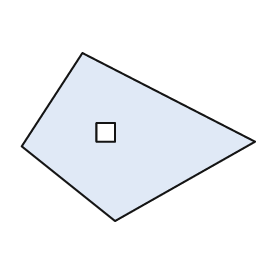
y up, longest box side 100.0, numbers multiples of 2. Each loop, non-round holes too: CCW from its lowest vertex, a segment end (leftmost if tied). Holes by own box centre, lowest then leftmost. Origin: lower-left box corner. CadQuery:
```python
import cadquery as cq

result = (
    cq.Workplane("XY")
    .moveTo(40.0, 0.0)
    .lineTo(100.0, 34.0)
    .lineTo(26.0, 72.0)
    .lineTo(0.0, 32.0)
    .close()
    .moveTo(32.0, 34.0)
    .lineTo(40.0, 34.0)
    .lineTo(40.0, 42.0)
    .lineTo(32.0, 42.0)
    .close()
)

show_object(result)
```